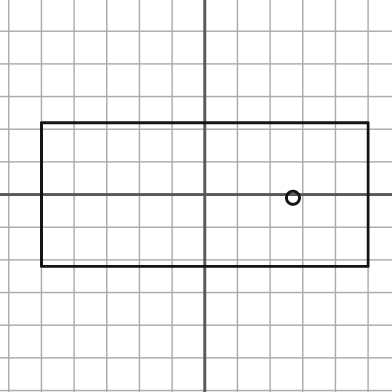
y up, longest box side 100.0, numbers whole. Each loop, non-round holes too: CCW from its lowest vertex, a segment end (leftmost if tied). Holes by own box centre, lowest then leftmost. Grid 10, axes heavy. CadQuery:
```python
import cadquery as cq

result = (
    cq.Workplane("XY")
    .moveTo(-50.0, -22.0)
    .lineTo(50.0, -22.0)
    .lineTo(50.0, 22.0)
    .lineTo(-50.0, 22.0)
    .close()
    .moveTo(27.0, -1.0)
    .circle(2.0)
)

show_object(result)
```